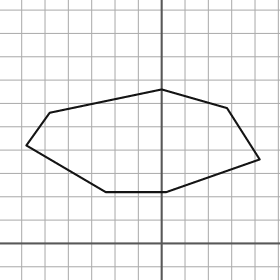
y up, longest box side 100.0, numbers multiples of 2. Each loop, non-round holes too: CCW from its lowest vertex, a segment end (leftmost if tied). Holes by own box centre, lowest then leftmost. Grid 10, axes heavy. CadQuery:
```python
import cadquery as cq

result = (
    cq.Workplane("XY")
    .moveTo(-24.0, 22.0)
    .lineTo(2.0, 22.0)
    .lineTo(42.0, 36.0)
    .lineTo(28.0, 58.0)
    .lineTo(0.0, 66.0)
    .lineTo(-48.0, 56.0)
    .lineTo(-58.0, 42.0)
    .close()
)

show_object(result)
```